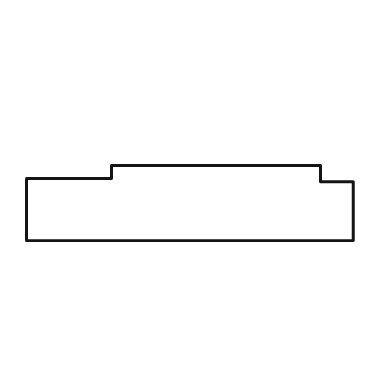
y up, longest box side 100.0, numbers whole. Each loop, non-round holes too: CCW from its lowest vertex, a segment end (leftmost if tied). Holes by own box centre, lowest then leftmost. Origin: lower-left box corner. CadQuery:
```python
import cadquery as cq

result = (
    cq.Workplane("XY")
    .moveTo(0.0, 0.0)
    .lineTo(100.0, 0.0)
    .lineTo(100.0, 18.0)
    .lineTo(90.0, 18.0)
    .lineTo(90.0, 23.0)
    .lineTo(26.0, 23.0)
    .lineTo(26.0, 19.0)
    .lineTo(0.0, 19.0)
    .close()
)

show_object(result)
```